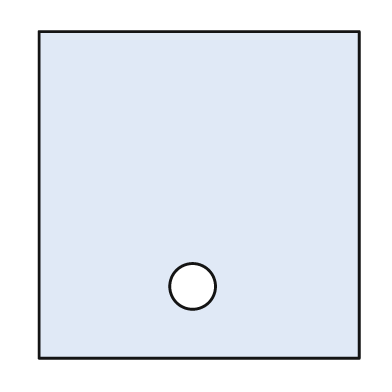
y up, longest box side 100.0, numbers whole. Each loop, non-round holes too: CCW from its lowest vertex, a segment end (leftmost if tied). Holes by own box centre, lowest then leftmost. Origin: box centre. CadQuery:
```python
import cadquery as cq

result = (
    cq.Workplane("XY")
    .moveTo(-49.0, -50.0)
    .lineTo(49.0, -50.0)
    .lineTo(49.0, 50.0)
    .lineTo(-49.0, 50.0)
    .close()
    .moveTo(-2.0, -28.0)
    .circle(7.0)
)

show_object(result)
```